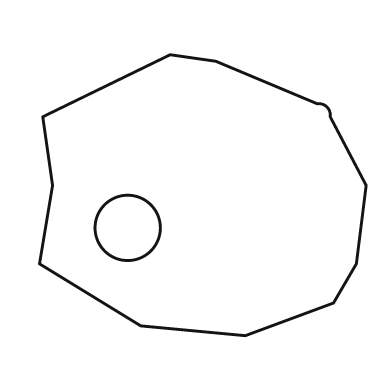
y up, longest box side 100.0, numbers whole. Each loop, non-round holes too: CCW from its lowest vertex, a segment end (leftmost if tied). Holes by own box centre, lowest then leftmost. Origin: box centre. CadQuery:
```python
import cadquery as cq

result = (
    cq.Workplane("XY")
    .moveTo(13.0, -43.0)
    .lineTo(40.0, -33.0)
    .lineTo(47.0, -21.0)
    .lineTo(50.0, 3.0)
    .lineTo(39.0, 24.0)
    .threePointArc((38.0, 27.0), (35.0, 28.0))
    .lineTo(4.0, 41.0)
    .lineTo(-10.0, 43.0)
    .lineTo(-49.0, 24.0)
    .lineTo(-46.0, 3.0)
    .lineTo(-50.0, -21.0)
    .lineTo(-19.0, -40.0)
    .close()
    .moveTo(-23.0, -10.0)
    .circle(10.0)
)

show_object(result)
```